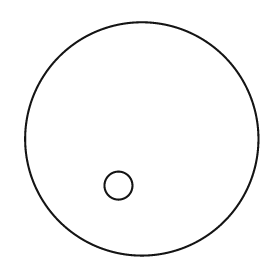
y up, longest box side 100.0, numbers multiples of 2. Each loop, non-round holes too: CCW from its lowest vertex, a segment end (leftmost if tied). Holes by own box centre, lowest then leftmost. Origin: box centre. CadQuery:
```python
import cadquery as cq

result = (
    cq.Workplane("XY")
    .moveTo(0.0, 0.0)
    .circle(50.0)
    .moveTo(-10.0, -20.0)
    .circle(6.0)
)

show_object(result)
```